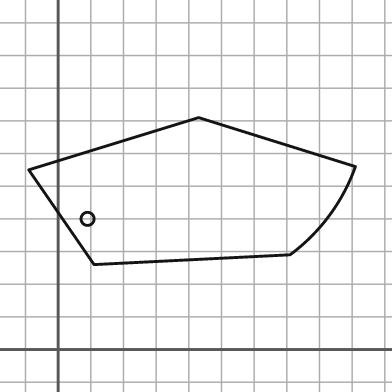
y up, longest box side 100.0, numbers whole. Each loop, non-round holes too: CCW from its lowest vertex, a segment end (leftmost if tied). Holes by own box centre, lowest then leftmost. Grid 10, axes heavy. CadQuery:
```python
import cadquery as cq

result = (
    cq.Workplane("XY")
    .moveTo(11.0, 26.0)
    .lineTo(71.0, 29.0)
    .threePointArc((83.0, 41.0), (91.0, 56.0))
    .lineTo(43.0, 71.0)
    .lineTo(-9.0, 55.0)
    .close()
    .moveTo(9.0, 40.0)
    .circle(2.0)
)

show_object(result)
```